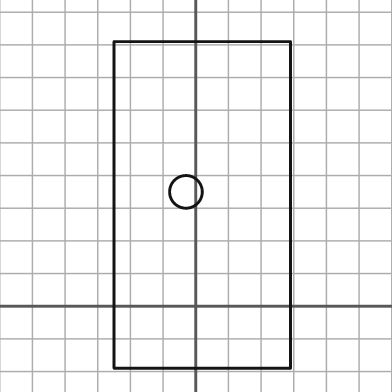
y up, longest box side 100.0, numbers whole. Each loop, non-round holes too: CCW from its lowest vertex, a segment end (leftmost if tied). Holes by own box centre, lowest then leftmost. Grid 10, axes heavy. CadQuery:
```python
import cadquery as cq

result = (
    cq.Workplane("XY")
    .moveTo(-25.0, -19.0)
    .lineTo(29.0, -19.0)
    .lineTo(29.0, 81.0)
    .lineTo(-25.0, 81.0)
    .close()
    .moveTo(-3.0, 35.0)
    .circle(5.0)
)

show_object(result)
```